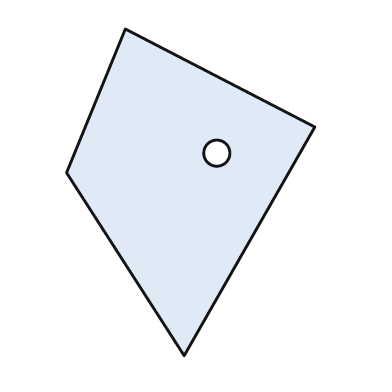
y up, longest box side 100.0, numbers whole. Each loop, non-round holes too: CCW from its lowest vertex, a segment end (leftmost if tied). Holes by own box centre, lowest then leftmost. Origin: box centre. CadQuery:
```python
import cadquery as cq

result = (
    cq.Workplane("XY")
    .moveTo(-2.0, -50.0)
    .lineTo(38.0, 20.0)
    .lineTo(-20.0, 50.0)
    .lineTo(-38.0, 6.0)
    .close()
    .moveTo(8.0, 12.0)
    .circle(4.0)
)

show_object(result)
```